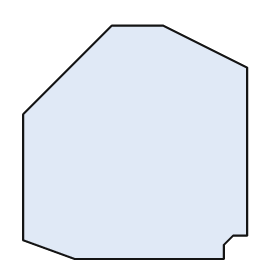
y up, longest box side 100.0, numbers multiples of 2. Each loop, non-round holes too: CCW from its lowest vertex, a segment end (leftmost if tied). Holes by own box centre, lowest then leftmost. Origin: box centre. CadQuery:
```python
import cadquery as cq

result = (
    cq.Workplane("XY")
    .moveTo(-26.0, -50.0)
    .lineTo(38.0, -50.0)
    .lineTo(38.0, -44.0)
    .lineTo(42.0, -40.0)
    .lineTo(48.0, -40.0)
    .lineTo(48.0, 32.0)
    .lineTo(12.0, 50.0)
    .lineTo(-10.0, 50.0)
    .lineTo(-48.0, 12.0)
    .lineTo(-48.0, -42.0)
    .close()
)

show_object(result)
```